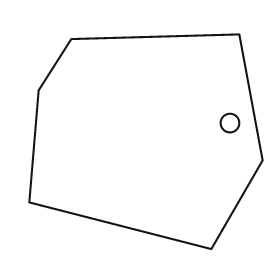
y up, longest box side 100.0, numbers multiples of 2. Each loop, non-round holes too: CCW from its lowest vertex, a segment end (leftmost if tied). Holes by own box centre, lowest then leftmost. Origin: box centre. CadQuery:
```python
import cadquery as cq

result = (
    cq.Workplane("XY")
    .moveTo(28.0, -46.0)
    .lineTo(50.0, -8.0)
    .lineTo(40.0, 46.0)
    .lineTo(-32.0, 44.0)
    .lineTo(-46.0, 22.0)
    .lineTo(-50.0, -26.0)
    .close()
    .moveTo(36.0, 8.0)
    .circle(4.0)
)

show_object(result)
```